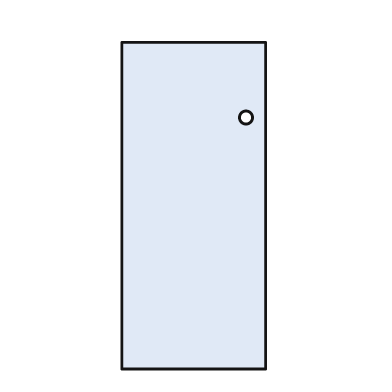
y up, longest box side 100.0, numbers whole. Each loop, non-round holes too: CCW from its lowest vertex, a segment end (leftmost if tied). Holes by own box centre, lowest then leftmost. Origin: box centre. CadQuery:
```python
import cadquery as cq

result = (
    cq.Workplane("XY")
    .moveTo(-22.0, -50.0)
    .lineTo(22.0, -50.0)
    .lineTo(22.0, 50.0)
    .lineTo(-22.0, 50.0)
    .close()
    .moveTo(16.0, 27.0)
    .circle(2.0)
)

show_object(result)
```